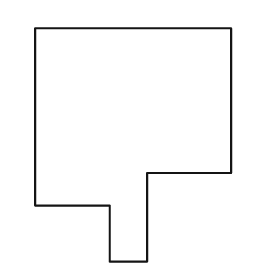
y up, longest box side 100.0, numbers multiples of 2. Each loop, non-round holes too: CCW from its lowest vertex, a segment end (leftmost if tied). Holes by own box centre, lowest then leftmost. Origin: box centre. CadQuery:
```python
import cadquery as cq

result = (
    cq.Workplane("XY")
    .moveTo(-10.0, -50.0)
    .lineTo(6.0, -50.0)
    .lineTo(6.0, -12.0)
    .lineTo(42.0, -12.0)
    .lineTo(42.0, 50.0)
    .lineTo(-42.0, 50.0)
    .lineTo(-42.0, -26.0)
    .lineTo(-10.0, -26.0)
    .close()
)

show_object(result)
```